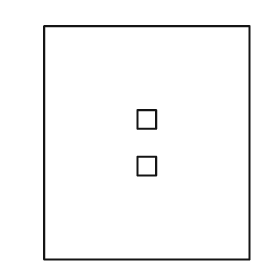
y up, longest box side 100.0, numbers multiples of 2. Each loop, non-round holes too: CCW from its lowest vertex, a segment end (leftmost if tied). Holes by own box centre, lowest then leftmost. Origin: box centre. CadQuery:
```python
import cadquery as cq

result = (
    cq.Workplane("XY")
    .moveTo(-44.0, -50.0)
    .lineTo(44.0, -50.0)
    .lineTo(44.0, 50.0)
    .lineTo(-44.0, 50.0)
    .close()
    .moveTo(-4.0, -14.0)
    .lineTo(4.0, -14.0)
    .lineTo(4.0, -6.0)
    .lineTo(-4.0, -6.0)
    .close()
    .moveTo(-4.0, 6.0)
    .lineTo(4.0, 6.0)
    .lineTo(4.0, 14.0)
    .lineTo(-4.0, 14.0)
    .close()
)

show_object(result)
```